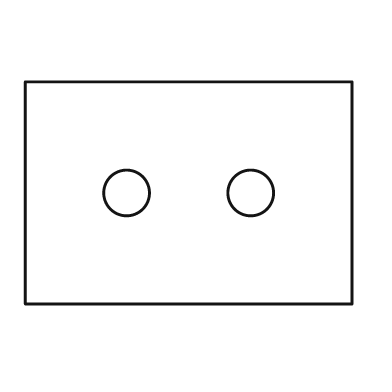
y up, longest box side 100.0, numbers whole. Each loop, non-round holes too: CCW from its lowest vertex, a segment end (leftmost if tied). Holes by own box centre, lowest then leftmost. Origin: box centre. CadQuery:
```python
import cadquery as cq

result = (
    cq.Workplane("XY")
    .moveTo(-50.0, -34.0)
    .lineTo(50.0, -34.0)
    .lineTo(50.0, 34.0)
    .lineTo(-50.0, 34.0)
    .close()
    .moveTo(-19.0, 0.0)
    .circle(7.0)
    .moveTo(19.0, 0.0)
    .circle(7.0)
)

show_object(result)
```